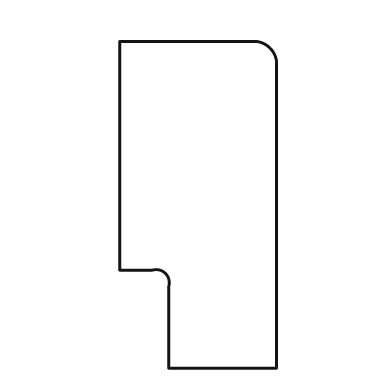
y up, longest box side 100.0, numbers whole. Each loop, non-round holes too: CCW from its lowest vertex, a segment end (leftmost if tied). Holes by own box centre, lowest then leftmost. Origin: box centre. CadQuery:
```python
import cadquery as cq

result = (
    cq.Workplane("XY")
    .moveTo(-9.0, -50.0)
    .lineTo(24.0, -50.0)
    .lineTo(24.0, 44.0)
    .threePointArc((22.0, 48.0), (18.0, 50.0))
    .lineTo(-24.0, 50.0)
    .lineTo(-24.0, -20.0)
    .lineTo(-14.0, -20.0)
    .threePointArc((-10.0, -21.0), (-9.0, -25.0))
    .close()
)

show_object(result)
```